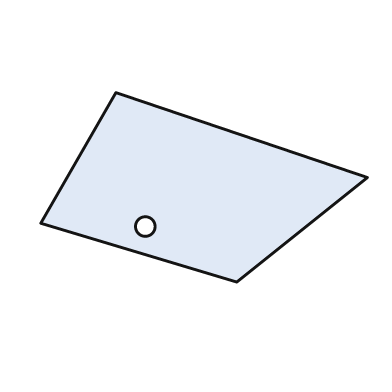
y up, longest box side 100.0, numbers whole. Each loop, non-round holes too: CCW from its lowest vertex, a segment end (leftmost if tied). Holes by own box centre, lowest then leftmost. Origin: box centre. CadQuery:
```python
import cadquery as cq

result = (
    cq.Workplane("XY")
    .moveTo(10.0, -29.0)
    .lineTo(50.0, 3.0)
    .lineTo(-27.0, 29.0)
    .lineTo(-50.0, -11.0)
    .close()
    .moveTo(-18.0, -12.0)
    .circle(3.0)
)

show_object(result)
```